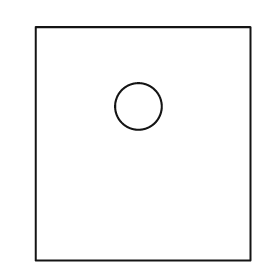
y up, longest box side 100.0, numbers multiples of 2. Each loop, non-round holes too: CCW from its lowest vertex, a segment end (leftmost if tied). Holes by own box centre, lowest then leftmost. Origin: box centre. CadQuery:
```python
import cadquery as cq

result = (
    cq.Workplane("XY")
    .moveTo(-46.0, -50.0)
    .lineTo(46.0, -50.0)
    .lineTo(46.0, 50.0)
    .lineTo(-46.0, 50.0)
    .close()
    .moveTo(-2.0, 16.0)
    .circle(10.0)
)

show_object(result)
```